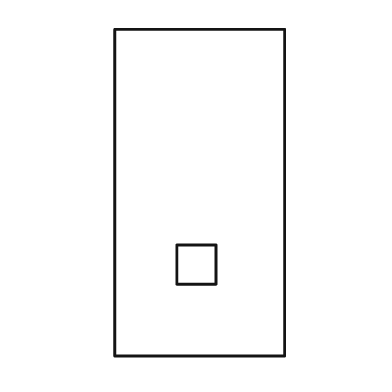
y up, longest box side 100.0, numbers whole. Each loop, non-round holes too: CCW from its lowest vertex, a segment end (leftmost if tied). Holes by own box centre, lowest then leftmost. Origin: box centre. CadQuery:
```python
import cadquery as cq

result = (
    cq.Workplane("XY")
    .moveTo(-26.0, -50.0)
    .lineTo(26.0, -50.0)
    .lineTo(26.0, 50.0)
    .lineTo(-26.0, 50.0)
    .close()
    .moveTo(-7.0, -28.0)
    .lineTo(5.0, -28.0)
    .lineTo(5.0, -16.0)
    .lineTo(-7.0, -16.0)
    .close()
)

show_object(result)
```